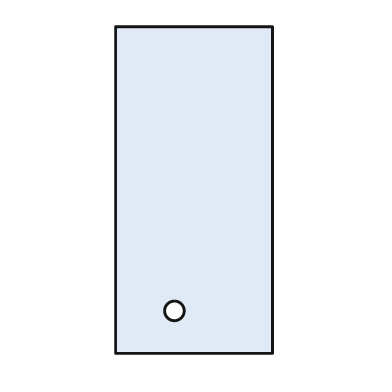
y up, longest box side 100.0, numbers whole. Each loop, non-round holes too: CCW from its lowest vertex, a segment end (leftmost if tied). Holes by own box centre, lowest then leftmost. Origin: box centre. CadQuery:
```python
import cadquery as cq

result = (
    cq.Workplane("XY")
    .moveTo(-24.0, -50.0)
    .lineTo(24.0, -50.0)
    .lineTo(24.0, 50.0)
    .lineTo(-24.0, 50.0)
    .close()
    .moveTo(-6.0, -37.0)
    .circle(3.0)
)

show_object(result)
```